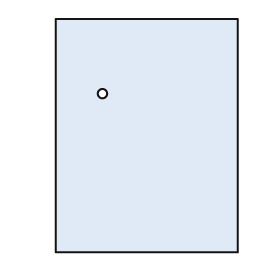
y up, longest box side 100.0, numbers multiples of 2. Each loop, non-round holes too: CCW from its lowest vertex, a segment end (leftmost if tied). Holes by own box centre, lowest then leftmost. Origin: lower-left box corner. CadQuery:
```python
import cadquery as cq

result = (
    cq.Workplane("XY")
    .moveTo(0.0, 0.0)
    .lineTo(78.0, 0.0)
    .lineTo(78.0, 100.0)
    .lineTo(0.0, 100.0)
    .close()
    .moveTo(20.0, 68.0)
    .circle(2.0)
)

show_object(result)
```